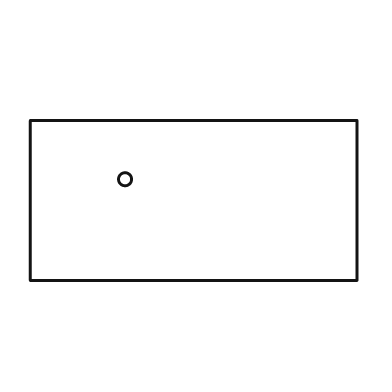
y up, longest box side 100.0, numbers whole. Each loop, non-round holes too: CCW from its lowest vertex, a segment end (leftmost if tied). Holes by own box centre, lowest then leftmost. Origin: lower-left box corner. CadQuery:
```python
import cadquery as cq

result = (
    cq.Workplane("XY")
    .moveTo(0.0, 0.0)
    .lineTo(100.0, 0.0)
    .lineTo(100.0, 49.0)
    .lineTo(0.0, 49.0)
    .close()
    .moveTo(29.0, 31.0)
    .circle(2.0)
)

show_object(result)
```